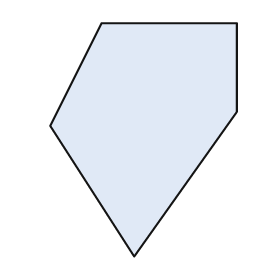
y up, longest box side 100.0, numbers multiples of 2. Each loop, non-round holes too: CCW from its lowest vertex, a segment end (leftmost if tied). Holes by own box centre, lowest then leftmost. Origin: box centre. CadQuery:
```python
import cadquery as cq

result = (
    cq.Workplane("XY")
    .moveTo(-4.0, -50.0)
    .lineTo(40.0, 12.0)
    .lineTo(40.0, 50.0)
    .lineTo(-18.0, 50.0)
    .lineTo(-40.0, 6.0)
    .close()
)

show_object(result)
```